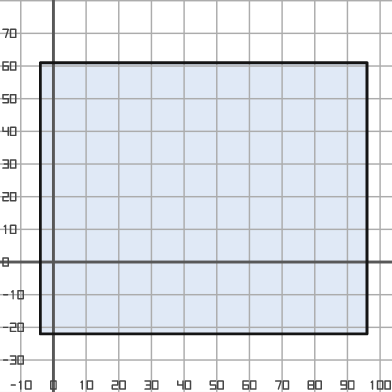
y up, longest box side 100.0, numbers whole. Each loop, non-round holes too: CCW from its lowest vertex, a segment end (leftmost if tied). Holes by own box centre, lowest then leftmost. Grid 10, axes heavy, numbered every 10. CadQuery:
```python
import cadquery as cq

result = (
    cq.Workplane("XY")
    .moveTo(-4.0, -22.0)
    .lineTo(96.0, -22.0)
    .lineTo(96.0, 61.0)
    .lineTo(-4.0, 61.0)
    .close()
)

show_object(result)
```